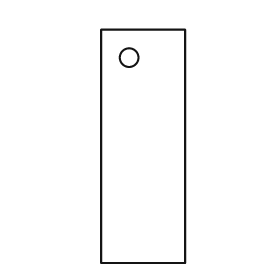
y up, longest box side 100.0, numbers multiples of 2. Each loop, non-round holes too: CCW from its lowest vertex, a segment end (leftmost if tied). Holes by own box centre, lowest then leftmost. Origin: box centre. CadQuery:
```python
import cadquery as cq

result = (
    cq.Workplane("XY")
    .moveTo(-18.0, -50.0)
    .lineTo(18.0, -50.0)
    .lineTo(18.0, 50.0)
    .lineTo(-18.0, 50.0)
    .close()
    .moveTo(-6.0, 38.0)
    .circle(4.0)
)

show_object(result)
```